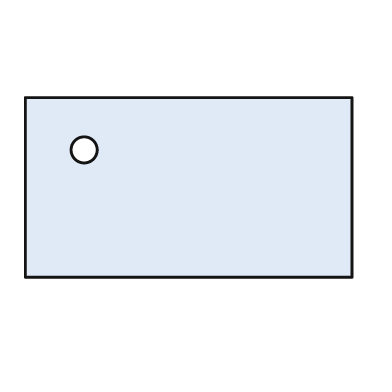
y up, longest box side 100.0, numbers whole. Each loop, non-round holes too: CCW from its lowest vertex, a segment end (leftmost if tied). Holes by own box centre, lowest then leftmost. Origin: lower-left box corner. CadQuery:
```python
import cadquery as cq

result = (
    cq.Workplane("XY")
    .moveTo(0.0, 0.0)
    .lineTo(100.0, 0.0)
    .lineTo(100.0, 55.0)
    .lineTo(0.0, 55.0)
    .close()
    .moveTo(18.0, 39.0)
    .circle(4.0)
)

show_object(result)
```